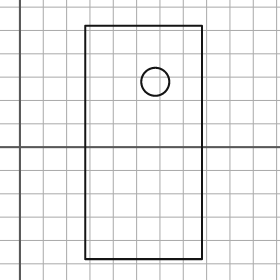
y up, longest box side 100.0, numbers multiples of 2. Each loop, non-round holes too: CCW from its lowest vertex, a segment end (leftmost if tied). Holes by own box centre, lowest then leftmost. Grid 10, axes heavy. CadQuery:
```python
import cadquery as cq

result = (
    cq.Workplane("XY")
    .moveTo(28.0, -48.0)
    .lineTo(78.0, -48.0)
    .lineTo(78.0, 52.0)
    .lineTo(28.0, 52.0)
    .close()
    .moveTo(58.0, 28.0)
    .circle(6.0)
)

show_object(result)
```